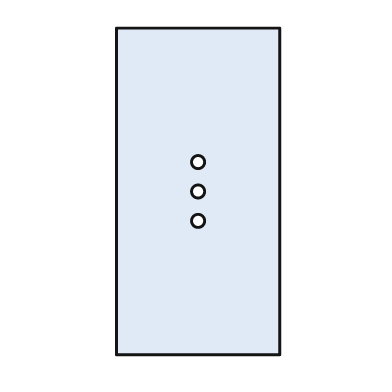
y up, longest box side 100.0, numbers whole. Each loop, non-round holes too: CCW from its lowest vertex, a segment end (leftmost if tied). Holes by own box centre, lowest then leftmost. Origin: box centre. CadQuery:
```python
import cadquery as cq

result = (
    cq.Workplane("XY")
    .moveTo(-25.0, -50.0)
    .lineTo(25.0, -50.0)
    .lineTo(25.0, 50.0)
    .lineTo(-25.0, 50.0)
    .close()
    .moveTo(0.0, -9.0)
    .circle(2.0)
    .moveTo(0.0, 0.0)
    .circle(2.0)
    .moveTo(0.0, 9.0)
    .circle(2.0)
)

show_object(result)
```